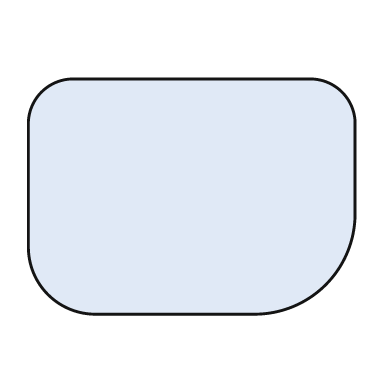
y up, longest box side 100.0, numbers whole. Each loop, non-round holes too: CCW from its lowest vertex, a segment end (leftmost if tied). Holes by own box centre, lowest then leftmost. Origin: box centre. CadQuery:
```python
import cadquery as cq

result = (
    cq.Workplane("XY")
    .moveTo(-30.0, -36.0)
    .lineTo(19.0, -36.0)
    .threePointArc((41.0, -27.0), (50.0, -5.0))
    .lineTo(50.0, 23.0)
    .threePointArc((46.0, 32.0), (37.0, 36.0))
    .lineTo(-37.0, 36.0)
    .threePointArc((-46.0, 32.0), (-50.0, 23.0))
    .lineTo(-50.0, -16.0)
    .threePointArc((-44.0, -30.0), (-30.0, -36.0))
    .close()
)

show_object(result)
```